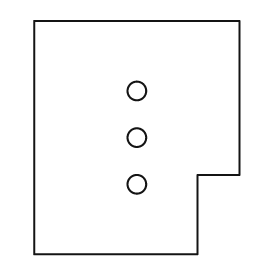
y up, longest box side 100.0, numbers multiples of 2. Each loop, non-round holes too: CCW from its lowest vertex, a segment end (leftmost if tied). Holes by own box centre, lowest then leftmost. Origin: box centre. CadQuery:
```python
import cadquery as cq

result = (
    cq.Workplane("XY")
    .moveTo(-44.0, -50.0)
    .lineTo(26.0, -50.0)
    .lineTo(26.0, -16.0)
    .lineTo(44.0, -16.0)
    .lineTo(44.0, 50.0)
    .lineTo(-44.0, 50.0)
    .close()
    .moveTo(0.0, -20.0)
    .circle(4.0)
    .moveTo(0.0, 0.0)
    .circle(4.0)
    .moveTo(0.0, 20.0)
    .circle(4.0)
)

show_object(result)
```